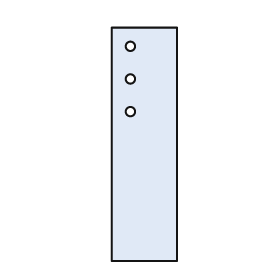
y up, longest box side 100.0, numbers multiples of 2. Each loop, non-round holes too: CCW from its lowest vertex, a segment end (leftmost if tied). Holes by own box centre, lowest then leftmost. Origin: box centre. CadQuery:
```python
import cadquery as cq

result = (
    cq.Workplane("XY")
    .moveTo(-14.0, -50.0)
    .lineTo(14.0, -50.0)
    .lineTo(14.0, 50.0)
    .lineTo(-14.0, 50.0)
    .close()
    .moveTo(-6.0, 14.0)
    .circle(2.0)
    .moveTo(-6.0, 28.0)
    .circle(2.0)
    .moveTo(-6.0, 42.0)
    .circle(2.0)
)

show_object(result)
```